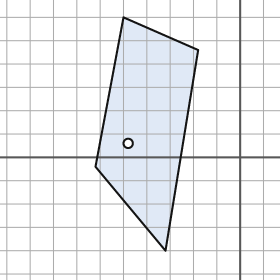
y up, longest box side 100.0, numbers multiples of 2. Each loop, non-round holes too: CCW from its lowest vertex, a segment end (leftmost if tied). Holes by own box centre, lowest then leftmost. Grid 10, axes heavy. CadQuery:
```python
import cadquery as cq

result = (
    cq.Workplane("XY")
    .moveTo(-32.0, -40.0)
    .lineTo(-18.0, 46.0)
    .lineTo(-50.0, 60.0)
    .lineTo(-62.0, -4.0)
    .close()
    .moveTo(-48.0, 6.0)
    .circle(2.0)
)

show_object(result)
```